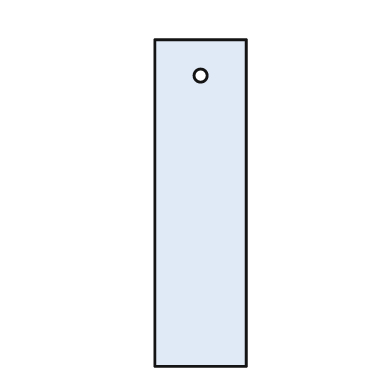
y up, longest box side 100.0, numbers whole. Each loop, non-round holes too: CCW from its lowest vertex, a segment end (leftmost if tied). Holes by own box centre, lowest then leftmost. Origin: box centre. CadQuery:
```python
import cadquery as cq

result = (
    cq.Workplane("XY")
    .moveTo(-14.0, -50.0)
    .lineTo(14.0, -50.0)
    .lineTo(14.0, 50.0)
    .lineTo(-14.0, 50.0)
    .close()
    .moveTo(0.0, 39.0)
    .circle(2.0)
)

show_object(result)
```